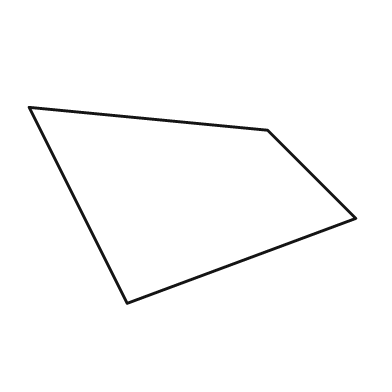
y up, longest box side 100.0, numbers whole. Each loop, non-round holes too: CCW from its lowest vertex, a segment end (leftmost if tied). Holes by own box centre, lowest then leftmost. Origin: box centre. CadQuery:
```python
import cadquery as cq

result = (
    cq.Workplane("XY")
    .moveTo(-20.0, -30.0)
    .lineTo(50.0, -4.0)
    .lineTo(23.0, 23.0)
    .lineTo(-50.0, 30.0)
    .close()
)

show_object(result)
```